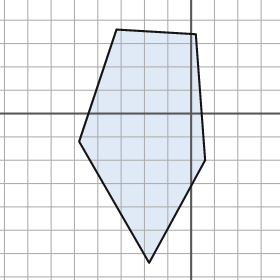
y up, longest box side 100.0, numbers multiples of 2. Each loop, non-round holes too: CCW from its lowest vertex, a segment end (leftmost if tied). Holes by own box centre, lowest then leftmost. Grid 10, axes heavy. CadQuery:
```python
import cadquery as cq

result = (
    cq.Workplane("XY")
    .moveTo(-18.0, -64.0)
    .lineTo(6.0, -20.0)
    .lineTo(2.0, 34.0)
    .lineTo(-32.0, 36.0)
    .lineTo(-48.0, -12.0)
    .close()
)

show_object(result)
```